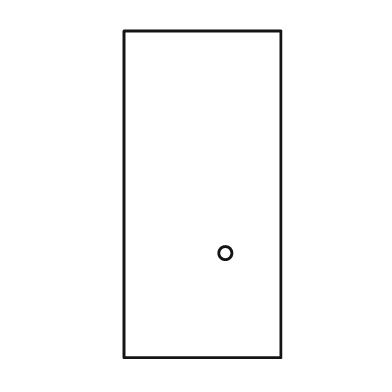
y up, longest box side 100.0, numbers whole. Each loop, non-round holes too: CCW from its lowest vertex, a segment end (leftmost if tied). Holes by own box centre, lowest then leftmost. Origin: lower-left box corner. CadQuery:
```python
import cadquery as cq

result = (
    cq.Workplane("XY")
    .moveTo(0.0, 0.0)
    .lineTo(48.0, 0.0)
    .lineTo(48.0, 100.0)
    .lineTo(0.0, 100.0)
    .close()
    .moveTo(31.0, 32.0)
    .circle(2.0)
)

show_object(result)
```